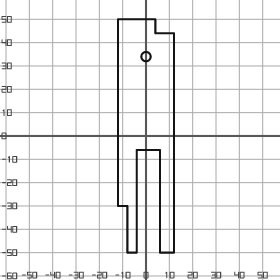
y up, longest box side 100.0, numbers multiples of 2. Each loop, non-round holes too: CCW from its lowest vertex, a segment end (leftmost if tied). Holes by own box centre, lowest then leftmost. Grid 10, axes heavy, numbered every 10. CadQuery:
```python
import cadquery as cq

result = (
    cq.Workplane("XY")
    .moveTo(-8.0, -50.0)
    .lineTo(-4.0, -50.0)
    .lineTo(-4.0, -6.0)
    .lineTo(6.0, -6.0)
    .lineTo(6.0, -50.0)
    .lineTo(12.0, -50.0)
    .lineTo(12.0, 44.0)
    .lineTo(4.0, 44.0)
    .lineTo(4.0, 50.0)
    .lineTo(-12.0, 50.0)
    .lineTo(-12.0, -30.0)
    .lineTo(-8.0, -30.0)
    .close()
    .moveTo(0.0, 34.0)
    .circle(2.0)
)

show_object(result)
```